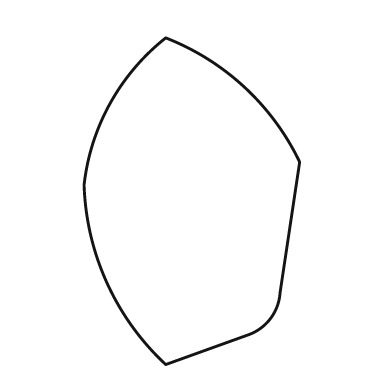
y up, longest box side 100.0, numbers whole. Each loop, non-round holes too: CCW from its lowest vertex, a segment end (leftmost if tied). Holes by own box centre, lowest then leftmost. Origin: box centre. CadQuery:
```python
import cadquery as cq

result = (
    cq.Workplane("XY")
    .moveTo(-8.0, -50.0)
    .lineTo(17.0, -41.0)
    .threePointArc((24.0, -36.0), (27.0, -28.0))
    .lineTo(33.0, 12.0)
    .threePointArc((16.0, 35.0), (-8.0, 50.0))
    .threePointArc((-25.0, 30.0), (-33.0, 5.0))
    .threePointArc((-26.0, -25.0), (-8.0, -50.0))
    .close()
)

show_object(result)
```